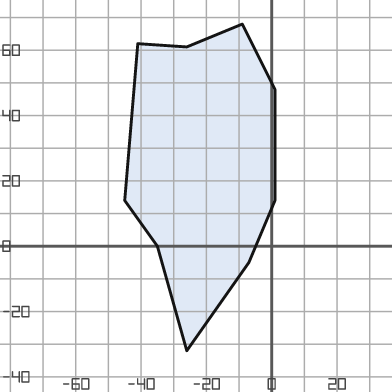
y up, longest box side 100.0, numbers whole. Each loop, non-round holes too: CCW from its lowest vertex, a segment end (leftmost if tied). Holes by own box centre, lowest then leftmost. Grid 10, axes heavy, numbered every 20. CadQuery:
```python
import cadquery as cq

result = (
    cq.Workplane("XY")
    .moveTo(-26.0, -32.0)
    .lineTo(-7.0, -5.0)
    .lineTo(1.0, 14.0)
    .lineTo(1.0, 48.0)
    .lineTo(-9.0, 68.0)
    .lineTo(-26.0, 61.0)
    .lineTo(-41.0, 62.0)
    .lineTo(-45.0, 14.0)
    .lineTo(-35.0, 0.0)
    .close()
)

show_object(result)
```